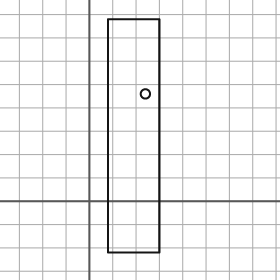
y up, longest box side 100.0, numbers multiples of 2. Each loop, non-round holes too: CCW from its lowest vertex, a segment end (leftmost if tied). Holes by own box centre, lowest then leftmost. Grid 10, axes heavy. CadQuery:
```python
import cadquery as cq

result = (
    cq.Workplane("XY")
    .moveTo(8.0, -22.0)
    .lineTo(30.0, -22.0)
    .lineTo(30.0, 78.0)
    .lineTo(8.0, 78.0)
    .close()
    .moveTo(24.0, 46.0)
    .circle(2.0)
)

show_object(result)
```